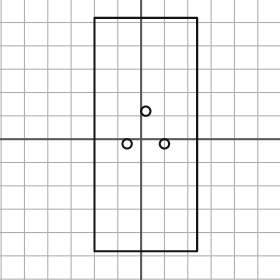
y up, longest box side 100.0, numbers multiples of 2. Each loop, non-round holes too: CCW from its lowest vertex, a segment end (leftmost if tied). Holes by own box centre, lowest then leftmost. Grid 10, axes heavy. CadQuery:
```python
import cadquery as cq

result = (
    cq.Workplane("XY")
    .moveTo(-20.0, -48.0)
    .lineTo(24.0, -48.0)
    .lineTo(24.0, 52.0)
    .lineTo(-20.0, 52.0)
    .close()
    .moveTo(-6.0, -2.0)
    .circle(2.0)
    .moveTo(10.0, -2.0)
    .circle(2.0)
    .moveTo(2.0, 12.0)
    .circle(2.0)
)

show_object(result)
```